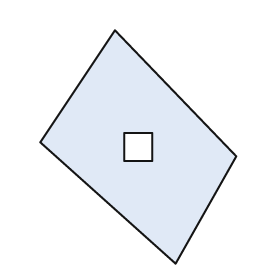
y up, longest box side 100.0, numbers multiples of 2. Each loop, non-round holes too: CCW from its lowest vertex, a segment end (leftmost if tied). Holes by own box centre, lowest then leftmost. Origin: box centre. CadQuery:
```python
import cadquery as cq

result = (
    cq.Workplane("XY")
    .moveTo(16.0, -50.0)
    .lineTo(42.0, -4.0)
    .lineTo(-10.0, 50.0)
    .lineTo(-42.0, 2.0)
    .close()
    .moveTo(-6.0, -6.0)
    .lineTo(6.0, -6.0)
    .lineTo(6.0, 6.0)
    .lineTo(-6.0, 6.0)
    .close()
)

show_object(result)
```